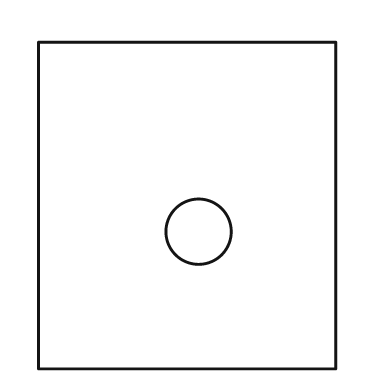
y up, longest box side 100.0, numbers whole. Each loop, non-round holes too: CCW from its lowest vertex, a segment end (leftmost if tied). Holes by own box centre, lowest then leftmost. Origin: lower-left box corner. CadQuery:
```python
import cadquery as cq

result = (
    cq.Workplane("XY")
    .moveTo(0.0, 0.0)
    .lineTo(91.0, 0.0)
    .lineTo(91.0, 100.0)
    .lineTo(0.0, 100.0)
    .close()
    .moveTo(49.0, 42.0)
    .circle(10.0)
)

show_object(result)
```